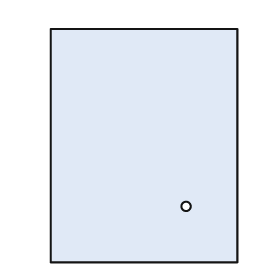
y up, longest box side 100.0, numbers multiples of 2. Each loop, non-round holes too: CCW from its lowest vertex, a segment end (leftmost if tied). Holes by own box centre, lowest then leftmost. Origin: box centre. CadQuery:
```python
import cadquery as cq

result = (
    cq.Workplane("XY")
    .moveTo(-40.0, -50.0)
    .lineTo(40.0, -50.0)
    .lineTo(40.0, 50.0)
    .lineTo(-40.0, 50.0)
    .close()
    .moveTo(18.0, -26.0)
    .circle(2.0)
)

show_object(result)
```